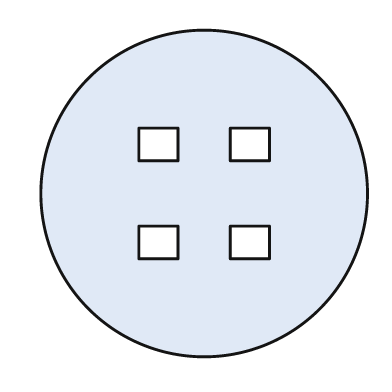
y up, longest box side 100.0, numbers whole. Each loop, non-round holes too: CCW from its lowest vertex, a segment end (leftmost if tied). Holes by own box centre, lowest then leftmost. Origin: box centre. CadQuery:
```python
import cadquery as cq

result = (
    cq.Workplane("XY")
    .moveTo(0.0, 0.0)
    .circle(50.0)
    .moveTo(-20.0, -20.0)
    .lineTo(-8.0, -20.0)
    .lineTo(-8.0, -10.0)
    .lineTo(-20.0, -10.0)
    .close()
    .moveTo(8.0, -20.0)
    .lineTo(20.0, -20.0)
    .lineTo(20.0, -10.0)
    .lineTo(8.0, -10.0)
    .close()
    .moveTo(-20.0, 10.0)
    .lineTo(-8.0, 10.0)
    .lineTo(-8.0, 20.0)
    .lineTo(-20.0, 20.0)
    .close()
    .moveTo(8.0, 10.0)
    .lineTo(20.0, 10.0)
    .lineTo(20.0, 20.0)
    .lineTo(8.0, 20.0)
    .close()
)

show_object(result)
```